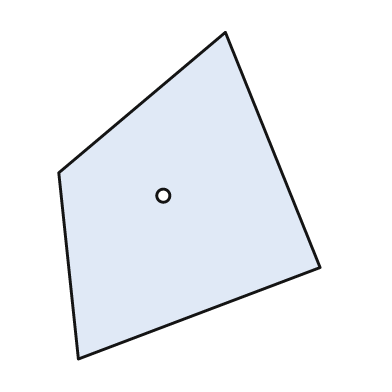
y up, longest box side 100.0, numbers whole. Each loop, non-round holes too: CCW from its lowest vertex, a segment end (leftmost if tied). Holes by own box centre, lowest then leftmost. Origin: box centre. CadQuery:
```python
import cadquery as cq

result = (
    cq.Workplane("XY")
    .moveTo(-34.0, -50.0)
    .lineTo(40.0, -22.0)
    .lineTo(11.0, 50.0)
    .lineTo(-40.0, 7.0)
    .close()
    .moveTo(-8.0, 0.0)
    .circle(2.0)
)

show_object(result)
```